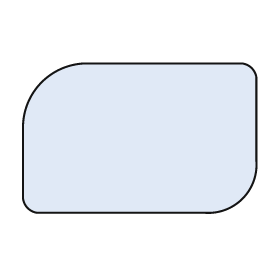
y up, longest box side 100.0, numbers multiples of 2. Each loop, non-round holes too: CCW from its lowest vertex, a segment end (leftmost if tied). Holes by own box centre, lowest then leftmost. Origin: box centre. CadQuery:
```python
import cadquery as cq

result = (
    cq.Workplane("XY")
    .moveTo(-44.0, -32.0)
    .lineTo(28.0, -32.0)
    .threePointArc((44.0, -26.0), (50.0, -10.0))
    .lineTo(50.0, 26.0)
    .threePointArc((48.0, 30.0), (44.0, 32.0))
    .lineTo(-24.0, 32.0)
    .threePointArc((-42.0, 24.0), (-50.0, 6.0))
    .lineTo(-50.0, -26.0)
    .threePointArc((-48.0, -30.0), (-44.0, -32.0))
    .close()
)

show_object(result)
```